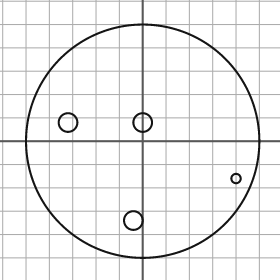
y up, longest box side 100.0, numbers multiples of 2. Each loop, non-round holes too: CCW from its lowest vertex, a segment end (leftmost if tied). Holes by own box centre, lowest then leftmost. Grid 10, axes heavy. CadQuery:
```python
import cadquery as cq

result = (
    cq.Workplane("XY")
    .moveTo(0.0, 0.0)
    .circle(50.0)
    .moveTo(-4.0, -34.0)
    .circle(4.0)
    .moveTo(40.0, -16.0)
    .circle(2.0)
    .moveTo(-32.0, 8.0)
    .circle(4.0)
    .moveTo(0.0, 8.0)
    .circle(4.0)
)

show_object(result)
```